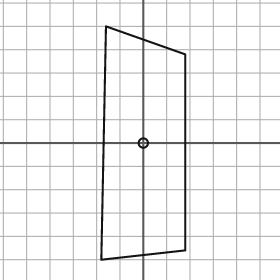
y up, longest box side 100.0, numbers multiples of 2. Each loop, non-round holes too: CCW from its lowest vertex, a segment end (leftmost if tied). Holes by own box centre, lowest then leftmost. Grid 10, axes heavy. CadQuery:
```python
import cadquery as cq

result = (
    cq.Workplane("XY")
    .moveTo(-18.0, -50.0)
    .lineTo(18.0, -46.0)
    .lineTo(18.0, 38.0)
    .lineTo(-16.0, 50.0)
    .close()
    .moveTo(0.0, 0.0)
    .circle(2.0)
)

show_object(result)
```